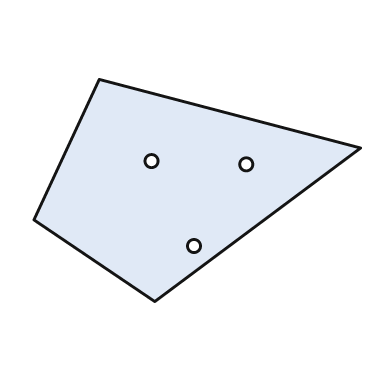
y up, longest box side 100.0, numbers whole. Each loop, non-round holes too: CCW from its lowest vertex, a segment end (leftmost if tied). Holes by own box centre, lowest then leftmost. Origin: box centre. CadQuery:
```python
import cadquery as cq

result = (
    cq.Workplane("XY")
    .moveTo(-13.0, -34.0)
    .lineTo(50.0, 13.0)
    .lineTo(-30.0, 34.0)
    .lineTo(-50.0, -9.0)
    .close()
    .moveTo(-1.0, -17.0)
    .circle(2.0)
    .moveTo(15.0, 8.0)
    .circle(2.0)
    .moveTo(-14.0, 9.0)
    .circle(2.0)
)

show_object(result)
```